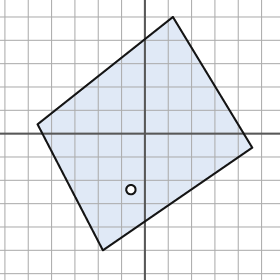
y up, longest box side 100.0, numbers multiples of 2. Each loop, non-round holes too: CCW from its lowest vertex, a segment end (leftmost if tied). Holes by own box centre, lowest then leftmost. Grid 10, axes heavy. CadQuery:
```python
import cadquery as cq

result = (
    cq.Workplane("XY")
    .moveTo(-18.0, -50.0)
    .lineTo(46.0, -6.0)
    .lineTo(12.0, 50.0)
    .lineTo(-46.0, 4.0)
    .close()
    .moveTo(-6.0, -24.0)
    .circle(2.0)
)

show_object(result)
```